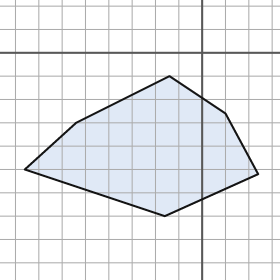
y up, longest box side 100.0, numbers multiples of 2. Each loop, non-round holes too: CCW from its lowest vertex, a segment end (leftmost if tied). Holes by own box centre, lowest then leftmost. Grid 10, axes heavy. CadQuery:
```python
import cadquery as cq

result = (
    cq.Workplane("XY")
    .moveTo(-16.0, -70.0)
    .lineTo(24.0, -52.0)
    .lineTo(10.0, -26.0)
    .lineTo(-14.0, -10.0)
    .lineTo(-54.0, -30.0)
    .lineTo(-76.0, -50.0)
    .close()
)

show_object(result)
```